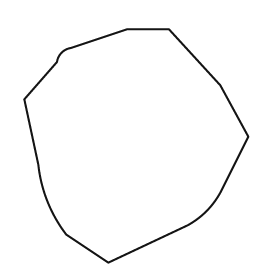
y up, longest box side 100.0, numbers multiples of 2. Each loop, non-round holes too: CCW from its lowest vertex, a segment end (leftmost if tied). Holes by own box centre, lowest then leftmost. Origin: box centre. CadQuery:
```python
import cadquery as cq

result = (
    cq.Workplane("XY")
    .moveTo(-12.0, -50.0)
    .lineTo(22.0, -34.0)
    .threePointArc((30.0, -28.0), (36.0, -20.0))
    .lineTo(48.0, 4.0)
    .lineTo(36.0, 26.0)
    .lineTo(14.0, 50.0)
    .lineTo(-4.0, 50.0)
    .lineTo(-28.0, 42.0)
    .threePointArc((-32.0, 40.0), (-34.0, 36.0))
    .lineTo(-48.0, 20.0)
    .lineTo(-42.0, -8.0)
    .threePointArc((-38.0, -24.0), (-30.0, -38.0))
    .close()
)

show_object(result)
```